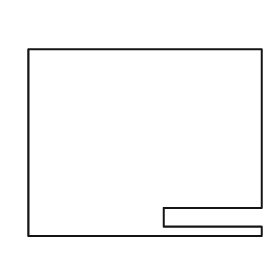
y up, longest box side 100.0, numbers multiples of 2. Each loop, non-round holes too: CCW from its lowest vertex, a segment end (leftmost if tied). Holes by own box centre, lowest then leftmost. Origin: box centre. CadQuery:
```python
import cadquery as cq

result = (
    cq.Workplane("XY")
    .moveTo(-50.0, -40.0)
    .lineTo(50.0, -40.0)
    .lineTo(50.0, -36.0)
    .lineTo(8.0, -36.0)
    .lineTo(8.0, -28.0)
    .lineTo(50.0, -28.0)
    .lineTo(50.0, 40.0)
    .lineTo(-50.0, 40.0)
    .close()
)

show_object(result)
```